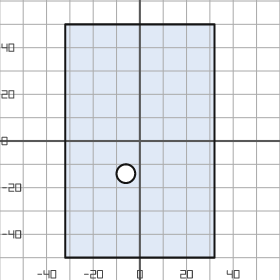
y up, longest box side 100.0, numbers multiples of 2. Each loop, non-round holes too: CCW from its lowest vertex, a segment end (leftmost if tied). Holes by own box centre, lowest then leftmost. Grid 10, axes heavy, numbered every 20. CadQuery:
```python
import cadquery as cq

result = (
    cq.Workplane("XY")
    .moveTo(-32.0, -50.0)
    .lineTo(32.0, -50.0)
    .lineTo(32.0, 50.0)
    .lineTo(-32.0, 50.0)
    .close()
    .moveTo(-6.0, -14.0)
    .circle(4.0)
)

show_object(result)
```